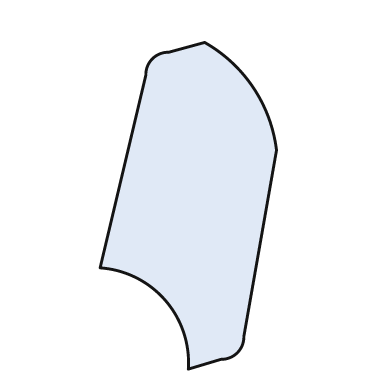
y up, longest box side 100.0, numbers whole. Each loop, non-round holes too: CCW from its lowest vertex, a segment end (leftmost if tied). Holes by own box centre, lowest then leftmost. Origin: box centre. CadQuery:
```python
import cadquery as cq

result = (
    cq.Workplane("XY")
    .moveTo(0.0, -50.0)
    .lineTo(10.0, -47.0)
    .threePointArc((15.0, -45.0), (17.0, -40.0))
    .lineTo(27.0, 17.0)
    .threePointArc((20.0, 36.0), (5.0, 50.0))
    .lineTo(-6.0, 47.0)
    .threePointArc((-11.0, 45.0), (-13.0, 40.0))
    .lineTo(-27.0, -19.0)
    .threePointArc((-7.0, -29.0), (0.0, -50.0))
    .close()
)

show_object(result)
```